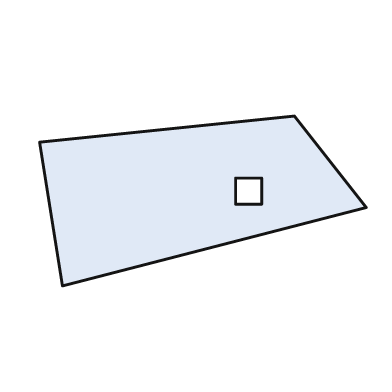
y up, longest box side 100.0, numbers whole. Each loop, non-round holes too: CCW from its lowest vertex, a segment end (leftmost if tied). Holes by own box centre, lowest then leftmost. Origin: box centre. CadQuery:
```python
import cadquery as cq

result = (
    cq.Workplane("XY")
    .moveTo(-43.0, -26.0)
    .lineTo(50.0, -2.0)
    .lineTo(28.0, 26.0)
    .lineTo(-50.0, 18.0)
    .close()
    .moveTo(10.0, -1.0)
    .lineTo(18.0, -1.0)
    .lineTo(18.0, 7.0)
    .lineTo(10.0, 7.0)
    .close()
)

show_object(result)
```